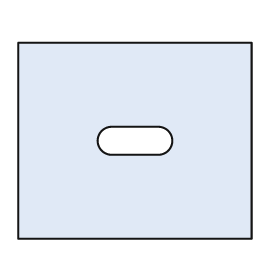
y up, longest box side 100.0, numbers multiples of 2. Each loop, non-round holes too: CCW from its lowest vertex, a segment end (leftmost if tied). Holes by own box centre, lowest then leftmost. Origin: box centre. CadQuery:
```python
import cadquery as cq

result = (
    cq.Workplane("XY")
    .moveTo(-50.0, -42.0)
    .lineTo(50.0, -42.0)
    .lineTo(50.0, 42.0)
    .lineTo(-50.0, 42.0)
    .close()
    .moveTo(-10.0, -6.0)
    .lineTo(10.0, -6.0)
    .threePointArc((16.0, 0.0), (10.0, 6.0))
    .lineTo(-10.0, 6.0)
    .threePointArc((-16.0, 0.0), (-10.0, -6.0))
    .close()
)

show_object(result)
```